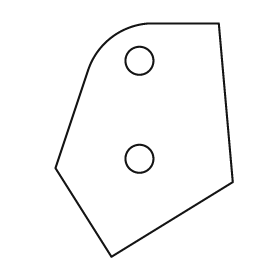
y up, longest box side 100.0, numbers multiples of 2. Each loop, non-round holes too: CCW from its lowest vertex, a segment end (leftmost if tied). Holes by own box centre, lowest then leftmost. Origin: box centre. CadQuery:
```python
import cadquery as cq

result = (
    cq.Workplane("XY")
    .moveTo(-14.0, -50.0)
    .lineTo(38.0, -18.0)
    .lineTo(32.0, 50.0)
    .lineTo(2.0, 50.0)
    .threePointArc((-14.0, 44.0), (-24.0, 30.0))
    .lineTo(-38.0, -12.0)
    .close()
    .moveTo(-2.0, -8.0)
    .circle(6.0)
    .moveTo(-2.0, 34.0)
    .circle(6.0)
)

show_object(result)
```